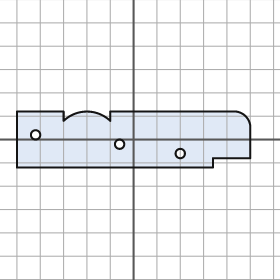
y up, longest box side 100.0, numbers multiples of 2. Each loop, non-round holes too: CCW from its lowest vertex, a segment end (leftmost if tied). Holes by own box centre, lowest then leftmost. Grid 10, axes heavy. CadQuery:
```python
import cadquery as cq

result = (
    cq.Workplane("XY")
    .moveTo(-50.0, -12.0)
    .lineTo(34.0, -12.0)
    .lineTo(34.0, -8.0)
    .lineTo(50.0, -8.0)
    .lineTo(50.0, 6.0)
    .threePointArc((48.0, 10.0), (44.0, 12.0))
    .lineTo(-10.0, 12.0)
    .lineTo(-10.0, 8.0)
    .threePointArc((-20.0, 12.0), (-30.0, 8.0))
    .lineTo(-30.0, 12.0)
    .lineTo(-50.0, 12.0)
    .close()
    .moveTo(20.0, -6.0)
    .circle(2.0)
    .moveTo(-6.0, -2.0)
    .circle(2.0)
    .moveTo(-42.0, 2.0)
    .circle(2.0)
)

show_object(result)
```